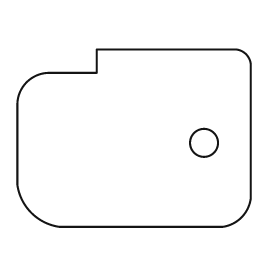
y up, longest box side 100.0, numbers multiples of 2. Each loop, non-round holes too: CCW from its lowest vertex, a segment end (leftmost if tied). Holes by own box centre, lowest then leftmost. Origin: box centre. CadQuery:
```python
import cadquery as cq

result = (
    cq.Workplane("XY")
    .moveTo(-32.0, -38.0)
    .lineTo(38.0, -38.0)
    .threePointArc((46.0, -34.0), (50.0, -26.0))
    .lineTo(50.0, 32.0)
    .threePointArc((48.0, 36.0), (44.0, 38.0))
    .lineTo(-16.0, 38.0)
    .lineTo(-16.0, 28.0)
    .lineTo(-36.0, 28.0)
    .threePointArc((-46.0, 24.0), (-50.0, 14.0))
    .lineTo(-50.0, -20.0)
    .threePointArc((-44.0, -32.0), (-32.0, -38.0))
    .close()
    .moveTo(30.0, -2.0)
    .circle(6.0)
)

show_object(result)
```